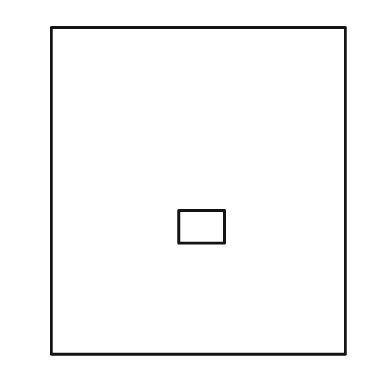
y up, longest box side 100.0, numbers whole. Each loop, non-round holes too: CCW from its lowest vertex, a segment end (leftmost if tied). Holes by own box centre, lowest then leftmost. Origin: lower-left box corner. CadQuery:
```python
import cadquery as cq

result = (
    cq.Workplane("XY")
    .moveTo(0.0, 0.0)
    .lineTo(90.0, 0.0)
    .lineTo(90.0, 100.0)
    .lineTo(0.0, 100.0)
    .close()
    .moveTo(39.0, 34.0)
    .lineTo(53.0, 34.0)
    .lineTo(53.0, 44.0)
    .lineTo(39.0, 44.0)
    .close()
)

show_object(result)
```